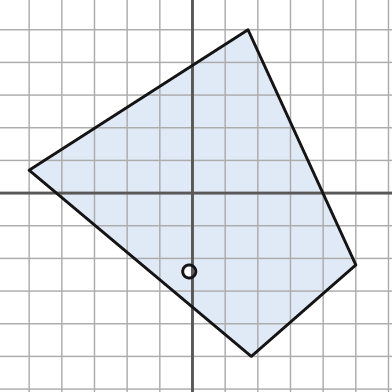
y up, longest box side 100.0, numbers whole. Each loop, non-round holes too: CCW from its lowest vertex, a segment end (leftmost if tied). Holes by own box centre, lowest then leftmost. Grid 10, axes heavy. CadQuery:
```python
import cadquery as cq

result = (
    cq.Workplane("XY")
    .moveTo(18.0, -50.0)
    .lineTo(50.0, -22.0)
    .lineTo(17.0, 50.0)
    .lineTo(-50.0, 7.0)
    .close()
    .moveTo(-1.0, -24.0)
    .circle(2.0)
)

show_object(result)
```